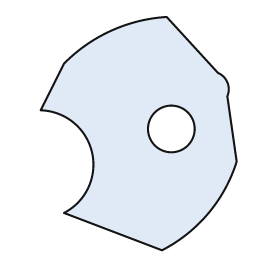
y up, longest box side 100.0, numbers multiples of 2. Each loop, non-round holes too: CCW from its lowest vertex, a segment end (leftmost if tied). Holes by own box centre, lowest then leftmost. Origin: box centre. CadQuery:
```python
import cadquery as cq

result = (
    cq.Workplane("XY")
    .moveTo(10.0, -50.0)
    .threePointArc((30.0, -34.0), (42.0, -12.0))
    .lineTo(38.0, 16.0)
    .threePointArc((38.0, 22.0), (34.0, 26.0))
    .lineTo(12.0, 50.0)
    .threePointArc((-12.0, 44.0), (-32.0, 30.0))
    .lineTo(-42.0, 10.0)
    .threePointArc((-20.0, -8.0), (-32.0, -34.0))
    .close()
    .moveTo(14.0, 2.0)
    .circle(10.0)
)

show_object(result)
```